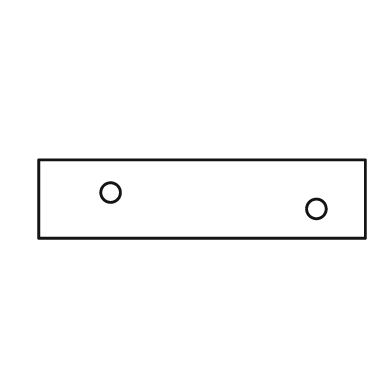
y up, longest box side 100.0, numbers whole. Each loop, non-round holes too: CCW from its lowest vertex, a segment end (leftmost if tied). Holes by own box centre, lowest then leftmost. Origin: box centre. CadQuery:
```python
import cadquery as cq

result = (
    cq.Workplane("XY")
    .moveTo(-50.0, -12.0)
    .lineTo(50.0, -12.0)
    .lineTo(50.0, 12.0)
    .lineTo(-50.0, 12.0)
    .close()
    .moveTo(35.0, -3.0)
    .circle(3.0)
    .moveTo(-28.0, 2.0)
    .circle(3.0)
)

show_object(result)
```